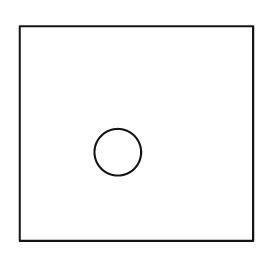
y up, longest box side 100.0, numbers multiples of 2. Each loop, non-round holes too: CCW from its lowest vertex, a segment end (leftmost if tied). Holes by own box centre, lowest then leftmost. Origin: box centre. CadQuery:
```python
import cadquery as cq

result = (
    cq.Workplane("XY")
    .moveTo(-50.0, -46.0)
    .lineTo(50.0, -46.0)
    .lineTo(50.0, 46.0)
    .lineTo(-50.0, 46.0)
    .close()
    .moveTo(-8.0, -8.0)
    .circle(10.0)
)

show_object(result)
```